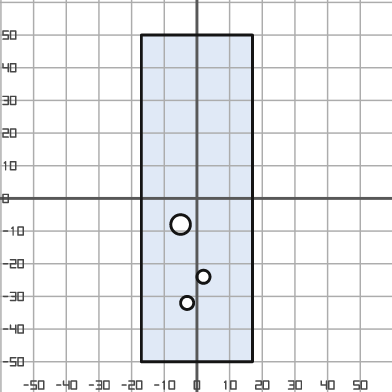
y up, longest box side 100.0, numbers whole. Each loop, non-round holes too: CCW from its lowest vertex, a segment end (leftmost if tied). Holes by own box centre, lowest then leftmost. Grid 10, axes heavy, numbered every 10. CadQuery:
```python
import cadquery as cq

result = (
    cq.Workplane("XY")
    .moveTo(-17.0, -50.0)
    .lineTo(17.0, -50.0)
    .lineTo(17.0, 50.0)
    .lineTo(-17.0, 50.0)
    .close()
    .moveTo(-3.0, -32.0)
    .circle(2.0)
    .moveTo(2.0, -24.0)
    .circle(2.0)
    .moveTo(-5.0, -8.0)
    .circle(3.0)
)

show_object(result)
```